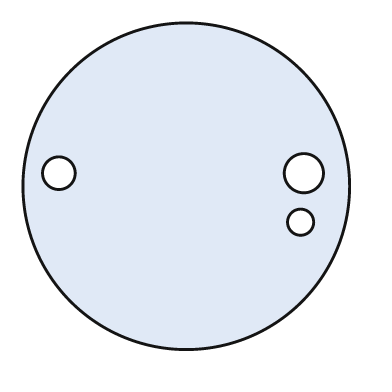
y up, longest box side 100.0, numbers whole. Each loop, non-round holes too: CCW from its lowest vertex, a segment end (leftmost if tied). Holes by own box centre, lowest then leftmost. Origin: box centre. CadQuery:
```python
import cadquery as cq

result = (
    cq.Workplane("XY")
    .moveTo(0.0, 0.0)
    .circle(50.0)
    .moveTo(35.0, -11.0)
    .circle(4.0)
    .moveTo(-39.0, 4.0)
    .circle(5.0)
    .moveTo(36.0, 4.0)
    .circle(6.0)
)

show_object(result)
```